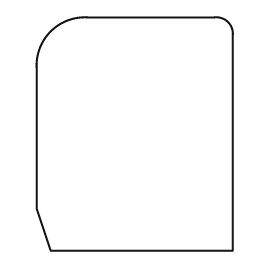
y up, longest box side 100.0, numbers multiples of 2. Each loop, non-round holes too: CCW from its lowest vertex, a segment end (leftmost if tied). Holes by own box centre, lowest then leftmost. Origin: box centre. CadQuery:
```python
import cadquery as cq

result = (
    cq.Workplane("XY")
    .moveTo(-36.0, -50.0)
    .lineTo(42.0, -50.0)
    .lineTo(42.0, 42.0)
    .threePointArc((40.0, 48.0), (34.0, 50.0))
    .lineTo(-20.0, 50.0)
    .threePointArc((-36.0, 44.0), (-42.0, 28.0))
    .lineTo(-42.0, -32.0)
    .close()
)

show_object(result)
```